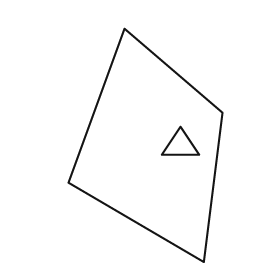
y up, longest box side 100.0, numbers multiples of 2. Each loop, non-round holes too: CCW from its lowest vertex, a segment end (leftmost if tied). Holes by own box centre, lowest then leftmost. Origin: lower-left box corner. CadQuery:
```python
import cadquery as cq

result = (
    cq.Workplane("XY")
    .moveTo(58.0, 0.0)
    .lineTo(66.0, 64.0)
    .lineTo(24.0, 100.0)
    .lineTo(0.0, 34.0)
    .close()
    .moveTo(40.0, 46.0)
    .lineTo(56.0, 46.0)
    .lineTo(48.0, 58.0)
    .close()
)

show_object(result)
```